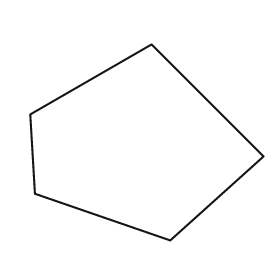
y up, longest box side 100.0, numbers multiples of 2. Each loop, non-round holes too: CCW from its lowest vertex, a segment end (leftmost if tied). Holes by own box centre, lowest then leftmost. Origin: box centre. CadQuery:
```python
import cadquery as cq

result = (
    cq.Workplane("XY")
    .moveTo(10.0, -42.0)
    .lineTo(50.0, -6.0)
    .lineTo(2.0, 42.0)
    .lineTo(-50.0, 12.0)
    .lineTo(-48.0, -22.0)
    .close()
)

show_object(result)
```